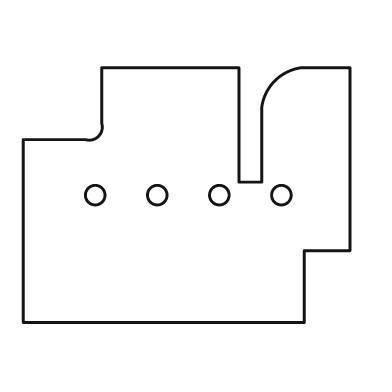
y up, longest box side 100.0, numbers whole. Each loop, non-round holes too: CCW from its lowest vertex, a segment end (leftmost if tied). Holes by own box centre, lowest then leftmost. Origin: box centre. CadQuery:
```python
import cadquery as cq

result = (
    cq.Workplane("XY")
    .moveTo(-50.0, -39.0)
    .lineTo(36.0, -39.0)
    .lineTo(36.0, -17.0)
    .lineTo(50.0, -17.0)
    .lineTo(50.0, 39.0)
    .lineTo(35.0, 39.0)
    .threePointArc((27.0, 35.0), (23.0, 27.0))
    .lineTo(23.0, 4.0)
    .lineTo(16.0, 4.0)
    .lineTo(16.0, 39.0)
    .lineTo(-26.0, 39.0)
    .lineTo(-26.0, 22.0)
    .threePointArc((-27.0, 18.0), (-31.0, 17.0))
    .lineTo(-50.0, 17.0)
    .close()
    .moveTo(-28.0, 0.0)
    .circle(3.0)
    .moveTo(-9.0, 0.0)
    .circle(3.0)
    .moveTo(10.0, 0.0)
    .circle(3.0)
    .moveTo(29.0, 0.0)
    .circle(3.0)
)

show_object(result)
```